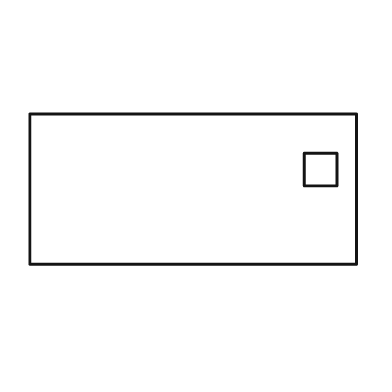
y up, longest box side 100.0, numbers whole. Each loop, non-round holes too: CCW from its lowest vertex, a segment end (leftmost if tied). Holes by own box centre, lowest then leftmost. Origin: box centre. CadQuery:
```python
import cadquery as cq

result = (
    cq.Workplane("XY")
    .moveTo(-50.0, -23.0)
    .lineTo(50.0, -23.0)
    .lineTo(50.0, 23.0)
    .lineTo(-50.0, 23.0)
    .close()
    .moveTo(34.0, 1.0)
    .lineTo(44.0, 1.0)
    .lineTo(44.0, 11.0)
    .lineTo(34.0, 11.0)
    .close()
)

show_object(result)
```